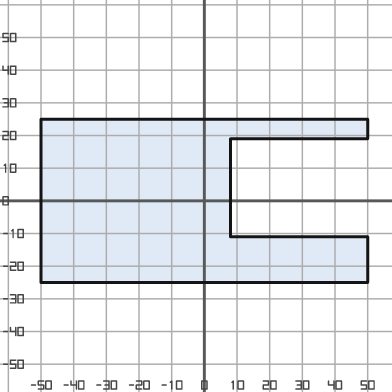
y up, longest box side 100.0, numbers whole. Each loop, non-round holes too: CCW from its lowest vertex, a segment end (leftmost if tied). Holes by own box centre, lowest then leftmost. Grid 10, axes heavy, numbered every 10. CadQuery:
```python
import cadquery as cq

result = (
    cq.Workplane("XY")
    .moveTo(-50.0, -25.0)
    .lineTo(50.0, -25.0)
    .lineTo(50.0, -11.0)
    .lineTo(8.0, -11.0)
    .lineTo(8.0, 19.0)
    .lineTo(50.0, 19.0)
    .lineTo(50.0, 25.0)
    .lineTo(-50.0, 25.0)
    .close()
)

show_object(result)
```